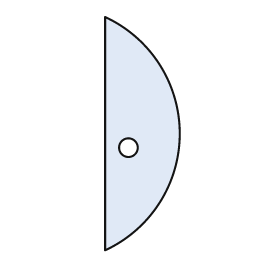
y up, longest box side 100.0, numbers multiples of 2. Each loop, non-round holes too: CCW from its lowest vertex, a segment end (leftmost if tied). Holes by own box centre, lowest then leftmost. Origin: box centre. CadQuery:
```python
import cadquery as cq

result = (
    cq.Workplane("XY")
    .moveTo(-16.0, -50.0)
    .threePointArc((16.0, 0.0), (-16.0, 50.0))
    .close()
    .moveTo(-6.0, -6.0)
    .circle(4.0)
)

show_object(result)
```